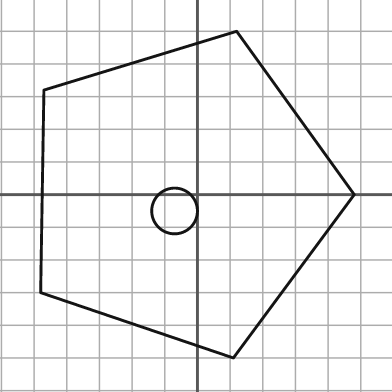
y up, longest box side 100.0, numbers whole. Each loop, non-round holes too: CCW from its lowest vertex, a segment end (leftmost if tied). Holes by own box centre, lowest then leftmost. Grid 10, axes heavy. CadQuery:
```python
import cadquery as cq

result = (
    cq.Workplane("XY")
    .moveTo(11.0, -50.0)
    .lineTo(48.0, 0.0)
    .lineTo(12.0, 50.0)
    .lineTo(-47.0, 32.0)
    .lineTo(-48.0, -30.0)
    .close()
    .moveTo(-7.0, -5.0)
    .circle(7.0)
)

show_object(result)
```